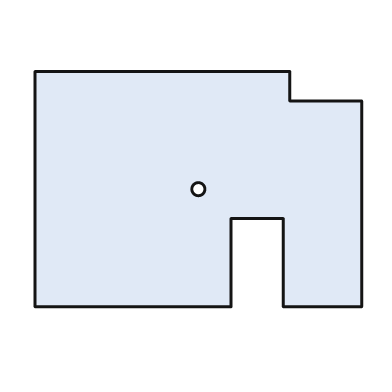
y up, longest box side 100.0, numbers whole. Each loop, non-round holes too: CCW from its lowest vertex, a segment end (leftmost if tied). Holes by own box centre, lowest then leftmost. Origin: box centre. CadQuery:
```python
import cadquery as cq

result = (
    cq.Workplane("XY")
    .moveTo(-50.0, -36.0)
    .lineTo(10.0, -36.0)
    .lineTo(10.0, -9.0)
    .lineTo(26.0, -9.0)
    .lineTo(26.0, -36.0)
    .lineTo(50.0, -36.0)
    .lineTo(50.0, 27.0)
    .lineTo(28.0, 27.0)
    .lineTo(28.0, 36.0)
    .lineTo(-50.0, 36.0)
    .close()
    .moveTo(0.0, 0.0)
    .circle(2.0)
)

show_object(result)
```